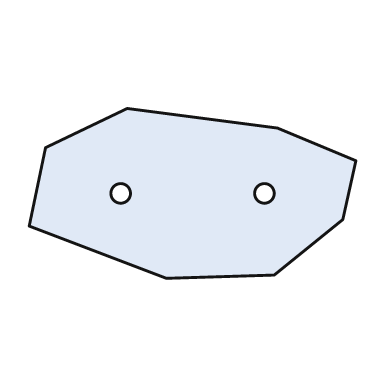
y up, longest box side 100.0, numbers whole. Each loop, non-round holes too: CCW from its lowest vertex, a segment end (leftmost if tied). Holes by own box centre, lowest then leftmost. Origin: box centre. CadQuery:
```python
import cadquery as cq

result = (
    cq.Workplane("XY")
    .moveTo(-8.0, -26.0)
    .lineTo(25.0, -25.0)
    .lineTo(46.0, -8.0)
    .lineTo(50.0, 10.0)
    .lineTo(26.0, 20.0)
    .lineTo(-20.0, 26.0)
    .lineTo(-45.0, 14.0)
    .lineTo(-50.0, -10.0)
    .close()
    .moveTo(-22.0, 0.0)
    .circle(3.0)
    .moveTo(22.0, 0.0)
    .circle(3.0)
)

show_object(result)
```